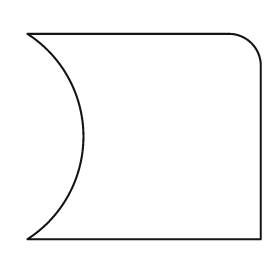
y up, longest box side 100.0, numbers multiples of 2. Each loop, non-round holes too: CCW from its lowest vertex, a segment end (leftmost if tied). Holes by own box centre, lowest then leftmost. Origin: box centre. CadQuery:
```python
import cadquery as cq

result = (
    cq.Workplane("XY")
    .moveTo(-50.0, -44.0)
    .lineTo(50.0, -44.0)
    .lineTo(50.0, 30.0)
    .threePointArc((46.0, 40.0), (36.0, 44.0))
    .lineTo(-50.0, 44.0)
    .threePointArc((-26.0, 0.0), (-50.0, -44.0))
    .close()
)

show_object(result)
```